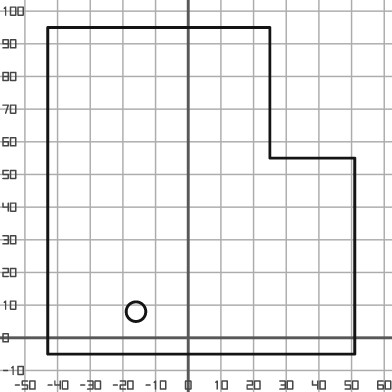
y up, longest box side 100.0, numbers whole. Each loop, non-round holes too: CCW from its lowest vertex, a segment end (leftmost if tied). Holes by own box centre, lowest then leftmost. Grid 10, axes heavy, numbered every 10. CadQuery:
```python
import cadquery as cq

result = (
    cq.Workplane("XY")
    .moveTo(-43.0, -5.0)
    .lineTo(51.0, -5.0)
    .lineTo(51.0, 55.0)
    .lineTo(25.0, 55.0)
    .lineTo(25.0, 95.0)
    .lineTo(-43.0, 95.0)
    .close()
    .moveTo(-16.0, 8.0)
    .circle(3.0)
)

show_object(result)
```